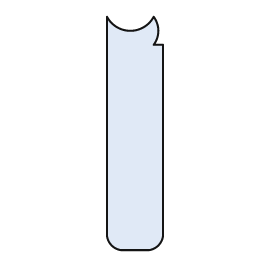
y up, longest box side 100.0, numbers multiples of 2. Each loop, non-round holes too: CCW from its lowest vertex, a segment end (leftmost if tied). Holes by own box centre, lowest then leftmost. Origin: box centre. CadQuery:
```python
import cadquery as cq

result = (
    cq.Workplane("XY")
    .moveTo(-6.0, -50.0)
    .lineTo(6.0, -50.0)
    .threePointArc((10.0, -48.0), (12.0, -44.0))
    .lineTo(12.0, 38.0)
    .lineTo(8.0, 38.0)
    .threePointArc((10.0, 44.0), (8.0, 50.0))
    .threePointArc((-2.0, 44.0), (-12.0, 50.0))
    .lineTo(-12.0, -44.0)
    .threePointArc((-10.0, -48.0), (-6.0, -50.0))
    .close()
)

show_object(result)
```